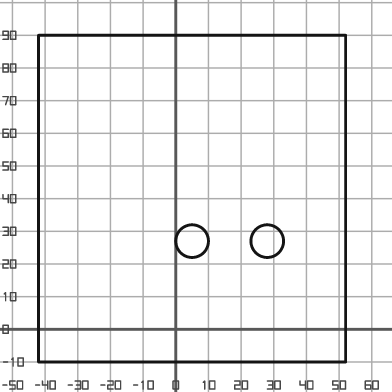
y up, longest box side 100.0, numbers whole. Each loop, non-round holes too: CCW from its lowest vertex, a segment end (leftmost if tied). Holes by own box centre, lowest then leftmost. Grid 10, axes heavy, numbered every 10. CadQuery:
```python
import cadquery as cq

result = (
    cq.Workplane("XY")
    .moveTo(-42.0, -10.0)
    .lineTo(52.0, -10.0)
    .lineTo(52.0, 90.0)
    .lineTo(-42.0, 90.0)
    .close()
    .moveTo(5.0, 27.0)
    .circle(5.0)
    .moveTo(28.0, 27.0)
    .circle(5.0)
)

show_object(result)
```